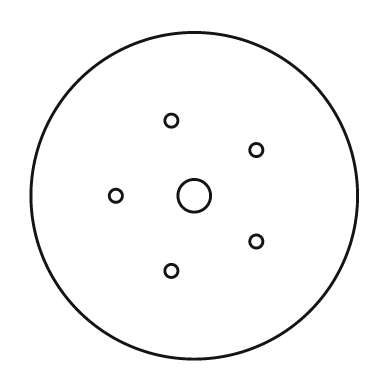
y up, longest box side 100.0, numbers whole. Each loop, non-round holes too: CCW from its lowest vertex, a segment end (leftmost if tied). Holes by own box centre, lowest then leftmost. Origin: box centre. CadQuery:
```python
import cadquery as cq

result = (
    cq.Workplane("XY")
    .moveTo(0.0, 0.0)
    .circle(50.0)
    .moveTo(-7.0, -23.0)
    .circle(2.0)
    .moveTo(19.0, -14.0)
    .circle(2.0)
    .moveTo(-24.0, 0.0)
    .circle(2.0)
    .moveTo(0.0, 0.0)
    .circle(5.0)
    .moveTo(19.0, 14.0)
    .circle(2.0)
    .moveTo(-7.0, 23.0)
    .circle(2.0)
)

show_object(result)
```